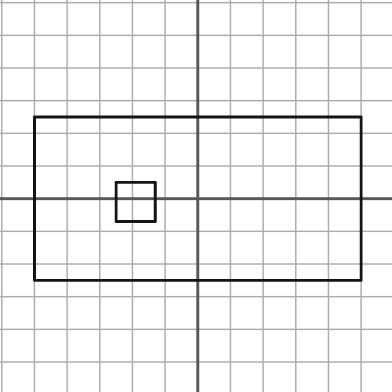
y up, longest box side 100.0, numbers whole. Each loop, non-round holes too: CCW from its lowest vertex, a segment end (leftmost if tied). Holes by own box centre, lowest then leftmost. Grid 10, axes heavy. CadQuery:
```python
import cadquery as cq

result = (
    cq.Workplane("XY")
    .moveTo(-50.0, -25.0)
    .lineTo(50.0, -25.0)
    .lineTo(50.0, 25.0)
    .lineTo(-50.0, 25.0)
    .close()
    .moveTo(-25.0, -7.0)
    .lineTo(-13.0, -7.0)
    .lineTo(-13.0, 5.0)
    .lineTo(-25.0, 5.0)
    .close()
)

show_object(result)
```